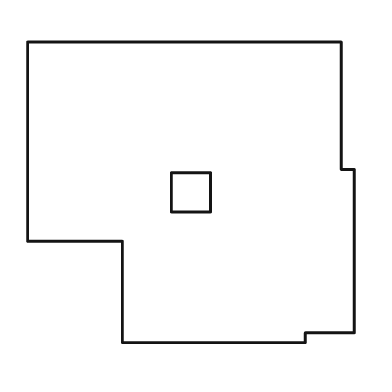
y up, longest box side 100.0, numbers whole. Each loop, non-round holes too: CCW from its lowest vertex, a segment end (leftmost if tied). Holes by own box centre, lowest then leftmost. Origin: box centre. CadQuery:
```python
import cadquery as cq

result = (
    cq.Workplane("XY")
    .moveTo(-21.0, -46.0)
    .lineTo(35.0, -46.0)
    .lineTo(35.0, -43.0)
    .lineTo(50.0, -43.0)
    .lineTo(50.0, 7.0)
    .lineTo(46.0, 7.0)
    .lineTo(46.0, 46.0)
    .lineTo(-50.0, 46.0)
    .lineTo(-50.0, -15.0)
    .lineTo(-21.0, -15.0)
    .close()
    .moveTo(-6.0, -6.0)
    .lineTo(6.0, -6.0)
    .lineTo(6.0, 6.0)
    .lineTo(-6.0, 6.0)
    .close()
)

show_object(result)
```